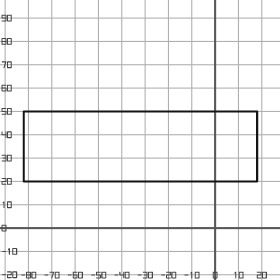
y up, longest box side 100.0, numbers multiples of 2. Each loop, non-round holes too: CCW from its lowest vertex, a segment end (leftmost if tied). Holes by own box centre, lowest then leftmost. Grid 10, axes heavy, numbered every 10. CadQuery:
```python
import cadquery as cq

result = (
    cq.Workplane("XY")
    .moveTo(-82.0, 20.0)
    .lineTo(18.0, 20.0)
    .lineTo(18.0, 50.0)
    .lineTo(-82.0, 50.0)
    .close()
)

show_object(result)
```